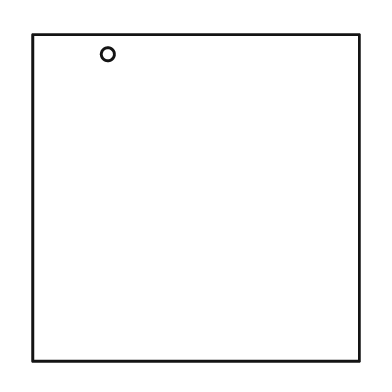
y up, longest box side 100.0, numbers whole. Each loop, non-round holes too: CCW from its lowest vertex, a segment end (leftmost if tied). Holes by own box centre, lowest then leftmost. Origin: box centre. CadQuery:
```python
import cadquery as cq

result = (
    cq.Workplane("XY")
    .moveTo(-50.0, -50.0)
    .lineTo(50.0, -50.0)
    .lineTo(50.0, 50.0)
    .lineTo(-50.0, 50.0)
    .close()
    .moveTo(-27.0, 44.0)
    .circle(2.0)
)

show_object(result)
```